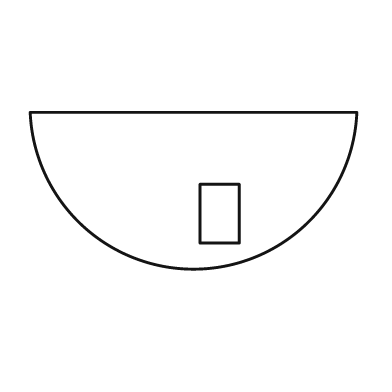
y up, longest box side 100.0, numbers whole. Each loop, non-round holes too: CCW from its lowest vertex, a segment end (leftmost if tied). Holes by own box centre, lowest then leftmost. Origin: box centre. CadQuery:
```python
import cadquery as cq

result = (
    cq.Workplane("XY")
    .moveTo(-50.0, 24.0)
    .threePointArc((0.0, -24.0), (50.0, 24.0))
    .close()
    .moveTo(2.0, -16.0)
    .lineTo(14.0, -16.0)
    .lineTo(14.0, 2.0)
    .lineTo(2.0, 2.0)
    .close()
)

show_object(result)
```